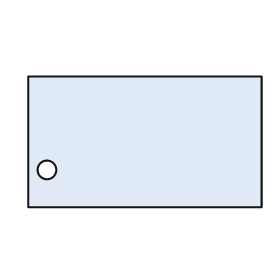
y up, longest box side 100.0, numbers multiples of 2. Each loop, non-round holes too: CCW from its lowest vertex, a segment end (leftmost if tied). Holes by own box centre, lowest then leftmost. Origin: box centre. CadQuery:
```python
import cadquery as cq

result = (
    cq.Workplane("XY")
    .moveTo(-50.0, -28.0)
    .lineTo(50.0, -28.0)
    .lineTo(50.0, 28.0)
    .lineTo(-50.0, 28.0)
    .close()
    .moveTo(-42.0, -12.0)
    .circle(4.0)
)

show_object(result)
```